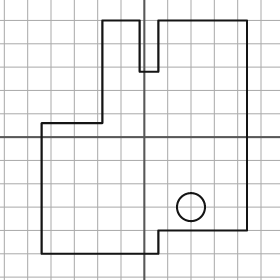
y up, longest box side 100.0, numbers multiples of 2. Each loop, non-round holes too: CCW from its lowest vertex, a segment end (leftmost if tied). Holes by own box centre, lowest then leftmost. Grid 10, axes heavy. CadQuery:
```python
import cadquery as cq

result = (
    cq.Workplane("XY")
    .moveTo(-44.0, -50.0)
    .lineTo(6.0, -50.0)
    .lineTo(6.0, -40.0)
    .lineTo(44.0, -40.0)
    .lineTo(44.0, 50.0)
    .lineTo(6.0, 50.0)
    .lineTo(6.0, 28.0)
    .lineTo(-2.0, 28.0)
    .lineTo(-2.0, 50.0)
    .lineTo(-18.0, 50.0)
    .lineTo(-18.0, 6.0)
    .lineTo(-44.0, 6.0)
    .close()
    .moveTo(20.0, -30.0)
    .circle(6.0)
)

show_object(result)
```